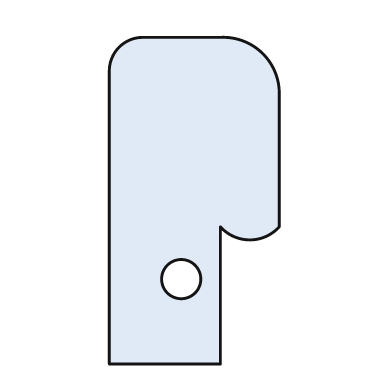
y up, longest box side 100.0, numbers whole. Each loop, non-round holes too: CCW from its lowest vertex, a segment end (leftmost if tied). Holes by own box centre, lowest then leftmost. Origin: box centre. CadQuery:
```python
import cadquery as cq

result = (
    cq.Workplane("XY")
    .moveTo(-26.0, -50.0)
    .lineTo(8.0, -50.0)
    .lineTo(8.0, -8.0)
    .threePointArc((17.0, -12.0), (26.0, -8.0))
    .lineTo(26.0, 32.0)
    .threePointArc((21.0, 45.0), (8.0, 50.0))
    .lineTo(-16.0, 50.0)
    .threePointArc((-23.0, 47.0), (-26.0, 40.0))
    .close()
    .moveTo(-4.0, -24.0)
    .circle(6.0)
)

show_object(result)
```